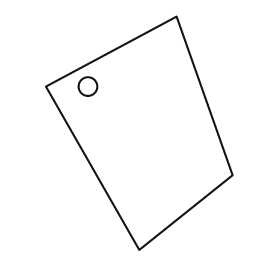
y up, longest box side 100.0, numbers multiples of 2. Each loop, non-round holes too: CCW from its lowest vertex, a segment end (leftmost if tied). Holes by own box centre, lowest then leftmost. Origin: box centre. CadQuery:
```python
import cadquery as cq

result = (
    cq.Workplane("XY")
    .moveTo(0.0, -50.0)
    .lineTo(40.0, -18.0)
    .lineTo(16.0, 50.0)
    .lineTo(-40.0, 20.0)
    .close()
    .moveTo(-22.0, 20.0)
    .circle(4.0)
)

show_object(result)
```